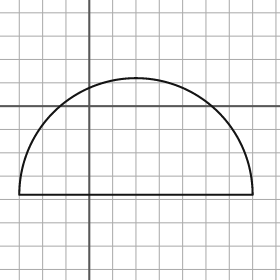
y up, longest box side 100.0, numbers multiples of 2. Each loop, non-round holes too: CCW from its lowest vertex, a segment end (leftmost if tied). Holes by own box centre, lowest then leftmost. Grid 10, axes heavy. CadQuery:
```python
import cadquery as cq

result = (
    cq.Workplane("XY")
    .moveTo(-30.0, -38.0)
    .lineTo(70.0, -38.0)
    .threePointArc((20.0, 12.0), (-30.0, -38.0))
    .close()
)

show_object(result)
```